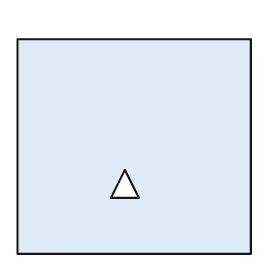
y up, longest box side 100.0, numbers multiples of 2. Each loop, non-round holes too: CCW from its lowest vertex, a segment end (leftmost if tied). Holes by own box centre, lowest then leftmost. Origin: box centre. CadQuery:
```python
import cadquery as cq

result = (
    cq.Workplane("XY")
    .moveTo(-50.0, -46.0)
    .lineTo(50.0, -46.0)
    .lineTo(50.0, 46.0)
    .lineTo(-50.0, 46.0)
    .close()
    .moveTo(-10.0, -22.0)
    .lineTo(2.0, -22.0)
    .lineTo(-4.0, -10.0)
    .close()
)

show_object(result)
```